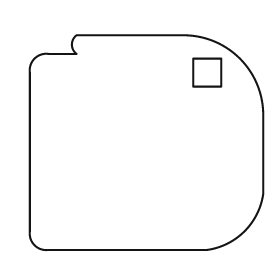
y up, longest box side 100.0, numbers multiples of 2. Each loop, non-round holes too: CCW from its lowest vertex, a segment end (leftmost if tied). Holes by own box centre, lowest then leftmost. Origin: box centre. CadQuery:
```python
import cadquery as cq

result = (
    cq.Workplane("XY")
    .moveTo(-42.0, -46.0)
    .lineTo(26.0, -46.0)
    .threePointArc((42.0, -38.0), (50.0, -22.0))
    .lineTo(50.0, 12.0)
    .threePointArc((40.0, 36.0), (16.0, 46.0))
    .lineTo(-30.0, 46.0)
    .threePointArc((-32.0, 42.0), (-30.0, 38.0))
    .lineTo(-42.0, 38.0)
    .threePointArc((-48.0, 36.0), (-50.0, 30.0))
    .lineTo(-50.0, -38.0)
    .threePointArc((-48.0, -44.0), (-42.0, -46.0))
    .close()
    .moveTo(20.0, 24.0)
    .lineTo(32.0, 24.0)
    .lineTo(32.0, 36.0)
    .lineTo(20.0, 36.0)
    .close()
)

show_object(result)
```